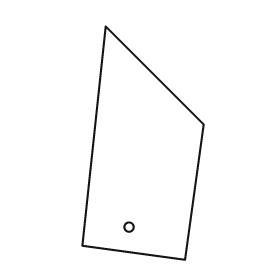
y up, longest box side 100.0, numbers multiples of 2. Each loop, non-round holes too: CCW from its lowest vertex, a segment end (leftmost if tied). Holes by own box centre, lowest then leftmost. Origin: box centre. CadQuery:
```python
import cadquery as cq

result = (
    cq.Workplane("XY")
    .moveTo(18.0, -50.0)
    .lineTo(26.0, 8.0)
    .lineTo(-16.0, 50.0)
    .lineTo(-26.0, -44.0)
    .close()
    .moveTo(-6.0, -36.0)
    .circle(2.0)
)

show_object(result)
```